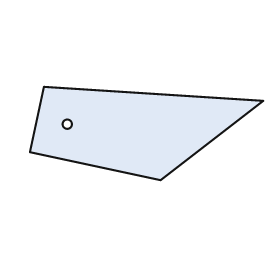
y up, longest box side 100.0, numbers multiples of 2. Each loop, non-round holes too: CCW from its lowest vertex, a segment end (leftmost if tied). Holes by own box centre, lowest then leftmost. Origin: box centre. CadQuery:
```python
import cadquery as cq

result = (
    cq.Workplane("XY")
    .moveTo(6.0, -20.0)
    .lineTo(50.0, 14.0)
    .lineTo(-44.0, 20.0)
    .lineTo(-50.0, -8.0)
    .close()
    .moveTo(-34.0, 4.0)
    .circle(2.0)
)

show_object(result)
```